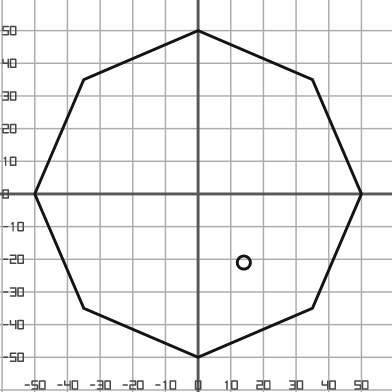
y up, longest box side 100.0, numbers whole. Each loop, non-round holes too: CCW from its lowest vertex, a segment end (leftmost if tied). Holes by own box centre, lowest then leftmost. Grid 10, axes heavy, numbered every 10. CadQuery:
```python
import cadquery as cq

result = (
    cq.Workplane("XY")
    .moveTo(0.0, -50.0)
    .lineTo(35.0, -35.0)
    .lineTo(50.0, 0.0)
    .lineTo(35.0, 35.0)
    .lineTo(0.0, 50.0)
    .lineTo(-35.0, 35.0)
    .lineTo(-50.0, 0.0)
    .lineTo(-35.0, -35.0)
    .close()
    .moveTo(14.0, -21.0)
    .circle(2.0)
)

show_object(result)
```